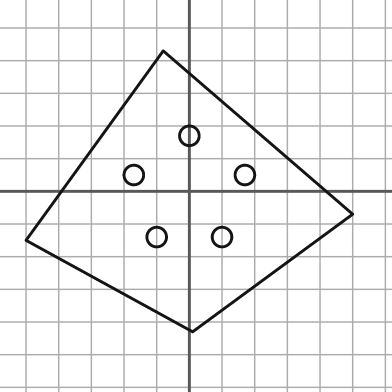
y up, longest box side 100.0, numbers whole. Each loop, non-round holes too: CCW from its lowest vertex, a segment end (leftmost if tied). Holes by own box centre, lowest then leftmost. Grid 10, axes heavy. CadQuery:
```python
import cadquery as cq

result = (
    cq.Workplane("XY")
    .moveTo(1.0, -43.0)
    .lineTo(50.0, -7.0)
    .lineTo(-8.0, 43.0)
    .lineTo(-50.0, -15.0)
    .close()
    .moveTo(-10.0, -14.0)
    .circle(3.0)
    .moveTo(10.0, -14.0)
    .circle(3.0)
    .moveTo(-17.0, 5.0)
    .circle(3.0)
    .moveTo(17.0, 5.0)
    .circle(3.0)
    .moveTo(0.0, 17.0)
    .circle(3.0)
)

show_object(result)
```